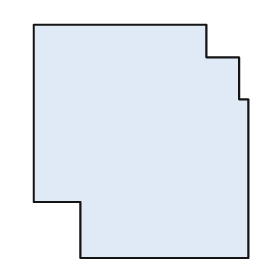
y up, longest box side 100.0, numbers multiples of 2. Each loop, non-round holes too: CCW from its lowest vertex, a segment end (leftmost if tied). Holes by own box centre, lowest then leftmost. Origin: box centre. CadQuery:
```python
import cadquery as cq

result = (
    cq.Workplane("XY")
    .moveTo(-26.0, -50.0)
    .lineTo(46.0, -50.0)
    .lineTo(46.0, 18.0)
    .lineTo(42.0, 18.0)
    .lineTo(42.0, 36.0)
    .lineTo(28.0, 36.0)
    .lineTo(28.0, 50.0)
    .lineTo(-46.0, 50.0)
    .lineTo(-46.0, -26.0)
    .lineTo(-26.0, -26.0)
    .close()
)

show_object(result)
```